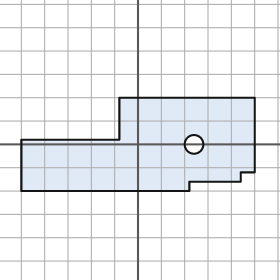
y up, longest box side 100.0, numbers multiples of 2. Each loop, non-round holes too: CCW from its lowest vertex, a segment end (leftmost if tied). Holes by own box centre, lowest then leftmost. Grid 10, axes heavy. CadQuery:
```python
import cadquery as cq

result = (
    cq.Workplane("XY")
    .moveTo(-50.0, -20.0)
    .lineTo(22.0, -20.0)
    .lineTo(22.0, -16.0)
    .lineTo(44.0, -16.0)
    .lineTo(44.0, -12.0)
    .lineTo(50.0, -12.0)
    .lineTo(50.0, 20.0)
    .lineTo(-8.0, 20.0)
    .lineTo(-8.0, 2.0)
    .lineTo(-50.0, 2.0)
    .close()
    .moveTo(24.0, 0.0)
    .circle(4.0)
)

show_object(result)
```